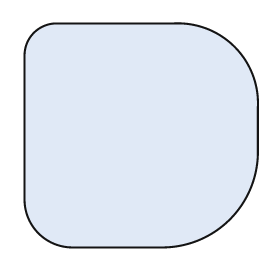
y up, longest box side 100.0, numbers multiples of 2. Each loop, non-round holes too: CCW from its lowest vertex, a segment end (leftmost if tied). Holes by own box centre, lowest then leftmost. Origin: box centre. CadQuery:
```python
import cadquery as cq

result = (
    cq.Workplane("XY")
    .moveTo(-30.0, -48.0)
    .lineTo(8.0, -48.0)
    .threePointArc((38.0, -36.0), (50.0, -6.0))
    .lineTo(50.0, 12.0)
    .threePointArc((40.0, 38.0), (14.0, 48.0))
    .lineTo(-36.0, 48.0)
    .threePointArc((-46.0, 44.0), (-50.0, 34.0))
    .lineTo(-50.0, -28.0)
    .threePointArc((-44.0, -42.0), (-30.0, -48.0))
    .close()
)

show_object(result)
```